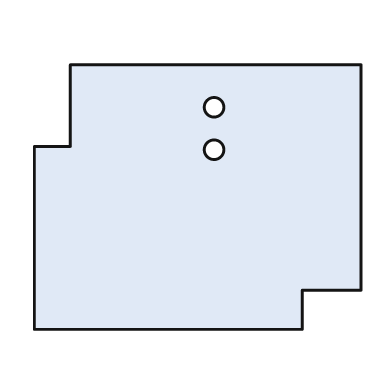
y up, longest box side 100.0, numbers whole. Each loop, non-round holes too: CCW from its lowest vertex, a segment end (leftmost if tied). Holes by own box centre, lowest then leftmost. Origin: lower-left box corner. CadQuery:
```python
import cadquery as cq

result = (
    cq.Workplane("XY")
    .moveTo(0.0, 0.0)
    .lineTo(82.0, 0.0)
    .lineTo(82.0, 12.0)
    .lineTo(100.0, 12.0)
    .lineTo(100.0, 81.0)
    .lineTo(11.0, 81.0)
    .lineTo(11.0, 56.0)
    .lineTo(0.0, 56.0)
    .close()
    .moveTo(55.0, 55.0)
    .circle(3.0)
    .moveTo(55.0, 68.0)
    .circle(3.0)
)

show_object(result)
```